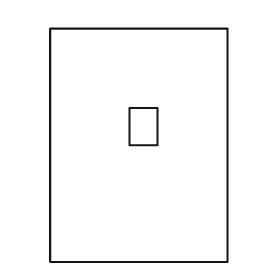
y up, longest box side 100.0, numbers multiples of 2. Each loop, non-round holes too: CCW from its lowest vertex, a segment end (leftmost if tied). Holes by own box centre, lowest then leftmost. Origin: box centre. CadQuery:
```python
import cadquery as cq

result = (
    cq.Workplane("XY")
    .moveTo(-38.0, -50.0)
    .lineTo(38.0, -50.0)
    .lineTo(38.0, 50.0)
    .lineTo(-38.0, 50.0)
    .close()
    .moveTo(-4.0, 0.0)
    .lineTo(8.0, 0.0)
    .lineTo(8.0, 16.0)
    .lineTo(-4.0, 16.0)
    .close()
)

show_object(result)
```